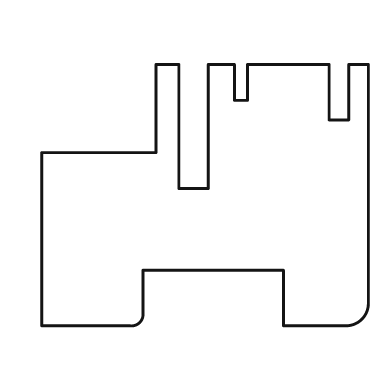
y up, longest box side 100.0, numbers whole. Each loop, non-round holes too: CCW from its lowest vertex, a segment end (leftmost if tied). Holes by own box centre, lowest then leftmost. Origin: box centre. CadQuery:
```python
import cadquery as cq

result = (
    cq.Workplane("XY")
    .moveTo(-50.0, -40.0)
    .lineTo(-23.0, -40.0)
    .threePointArc((-20.0, -39.0), (-19.0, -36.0))
    .lineTo(-19.0, -23.0)
    .lineTo(24.0, -23.0)
    .lineTo(24.0, -40.0)
    .lineTo(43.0, -40.0)
    .threePointArc((48.0, -38.0), (50.0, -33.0))
    .lineTo(50.0, 40.0)
    .lineTo(44.0, 40.0)
    .lineTo(44.0, 23.0)
    .lineTo(38.0, 23.0)
    .lineTo(38.0, 40.0)
    .lineTo(13.0, 40.0)
    .lineTo(13.0, 29.0)
    .lineTo(9.0, 29.0)
    .lineTo(9.0, 40.0)
    .lineTo(1.0, 40.0)
    .lineTo(1.0, 2.0)
    .lineTo(-8.0, 2.0)
    .lineTo(-8.0, 40.0)
    .lineTo(-15.0, 40.0)
    .lineTo(-15.0, 13.0)
    .lineTo(-50.0, 13.0)
    .close()
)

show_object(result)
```